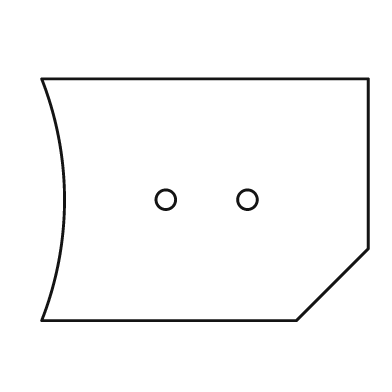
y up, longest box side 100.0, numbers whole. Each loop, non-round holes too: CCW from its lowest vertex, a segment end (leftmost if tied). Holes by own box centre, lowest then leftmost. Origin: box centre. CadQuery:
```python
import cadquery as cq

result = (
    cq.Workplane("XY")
    .moveTo(-50.0, -37.0)
    .lineTo(28.0, -37.0)
    .lineTo(50.0, -15.0)
    .lineTo(50.0, 37.0)
    .lineTo(-50.0, 37.0)
    .threePointArc((-43.0, 0.0), (-50.0, -37.0))
    .close()
    .moveTo(-12.0, 0.0)
    .circle(3.0)
    .moveTo(13.0, 0.0)
    .circle(3.0)
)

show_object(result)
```